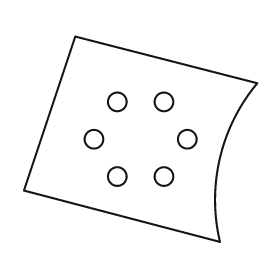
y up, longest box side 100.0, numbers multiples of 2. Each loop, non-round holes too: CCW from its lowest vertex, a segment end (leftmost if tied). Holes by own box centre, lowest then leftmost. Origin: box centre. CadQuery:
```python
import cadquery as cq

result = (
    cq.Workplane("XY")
    .moveTo(34.0, -44.0)
    .threePointArc((34.0, -8.0), (50.0, 24.0))
    .lineTo(-28.0, 44.0)
    .lineTo(-50.0, -22.0)
    .close()
    .moveTo(-10.0, -16.0)
    .circle(4.0)
    .moveTo(10.0, -16.0)
    .circle(4.0)
    .moveTo(-20.0, 0.0)
    .circle(4.0)
    .moveTo(20.0, 0.0)
    .circle(4.0)
    .moveTo(-10.0, 16.0)
    .circle(4.0)
    .moveTo(10.0, 16.0)
    .circle(4.0)
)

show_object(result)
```